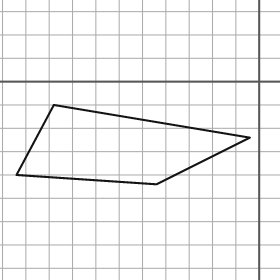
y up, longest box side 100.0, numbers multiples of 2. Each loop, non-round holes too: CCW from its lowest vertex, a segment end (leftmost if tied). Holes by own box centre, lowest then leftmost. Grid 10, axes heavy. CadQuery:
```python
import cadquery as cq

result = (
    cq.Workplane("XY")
    .moveTo(-44.0, -44.0)
    .lineTo(-4.0, -24.0)
    .lineTo(-88.0, -10.0)
    .lineTo(-104.0, -40.0)
    .close()
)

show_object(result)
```